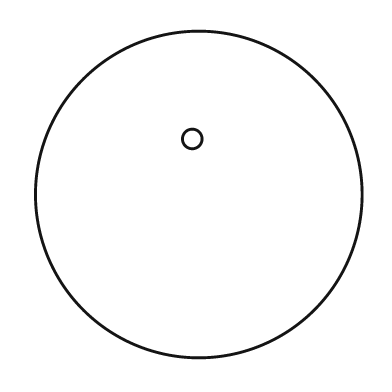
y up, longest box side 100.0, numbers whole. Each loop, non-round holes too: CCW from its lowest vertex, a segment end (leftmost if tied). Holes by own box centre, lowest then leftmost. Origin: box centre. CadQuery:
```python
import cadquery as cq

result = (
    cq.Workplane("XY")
    .moveTo(0.0, 0.0)
    .circle(50.0)
    .moveTo(-2.0, 17.0)
    .circle(3.0)
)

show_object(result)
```